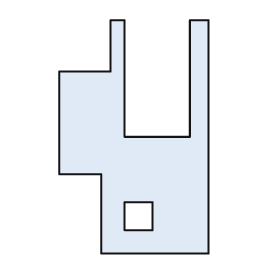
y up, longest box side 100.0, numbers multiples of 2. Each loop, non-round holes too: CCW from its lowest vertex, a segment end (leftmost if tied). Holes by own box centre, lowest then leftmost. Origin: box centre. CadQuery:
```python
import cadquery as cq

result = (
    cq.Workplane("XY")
    .moveTo(-14.0, -50.0)
    .lineTo(32.0, -50.0)
    .lineTo(32.0, 50.0)
    .lineTo(24.0, 50.0)
    .lineTo(24.0, 0.0)
    .lineTo(-4.0, 0.0)
    .lineTo(-4.0, 50.0)
    .lineTo(-10.0, 50.0)
    .lineTo(-10.0, 28.0)
    .lineTo(-32.0, 28.0)
    .lineTo(-32.0, -16.0)
    .lineTo(-14.0, -16.0)
    .close()
    .moveTo(-4.0, -40.0)
    .lineTo(8.0, -40.0)
    .lineTo(8.0, -28.0)
    .lineTo(-4.0, -28.0)
    .close()
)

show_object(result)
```